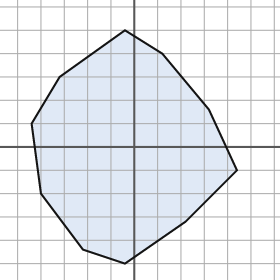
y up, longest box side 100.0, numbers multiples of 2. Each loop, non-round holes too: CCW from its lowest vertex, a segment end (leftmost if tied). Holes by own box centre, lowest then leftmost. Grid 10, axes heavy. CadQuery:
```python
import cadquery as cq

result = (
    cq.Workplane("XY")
    .moveTo(-4.0, -50.0)
    .lineTo(22.0, -32.0)
    .lineTo(44.0, -10.0)
    .lineTo(32.0, 16.0)
    .lineTo(12.0, 40.0)
    .lineTo(-4.0, 50.0)
    .lineTo(-32.0, 30.0)
    .lineTo(-44.0, 10.0)
    .lineTo(-40.0, -20.0)
    .lineTo(-22.0, -44.0)
    .close()
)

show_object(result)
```